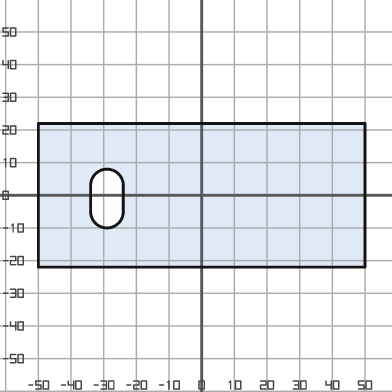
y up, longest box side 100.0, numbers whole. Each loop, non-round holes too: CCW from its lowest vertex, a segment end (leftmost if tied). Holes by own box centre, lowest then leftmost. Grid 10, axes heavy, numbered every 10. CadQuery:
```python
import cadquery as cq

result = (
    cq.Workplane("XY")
    .moveTo(-50.0, -22.0)
    .lineTo(50.0, -22.0)
    .lineTo(50.0, 22.0)
    .lineTo(-50.0, 22.0)
    .close()
    .moveTo(-34.0, -5.0)
    .threePointArc((-29.0, -10.0), (-24.0, -5.0))
    .lineTo(-24.0, 3.0)
    .threePointArc((-29.0, 8.0), (-34.0, 3.0))
    .close()
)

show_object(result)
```